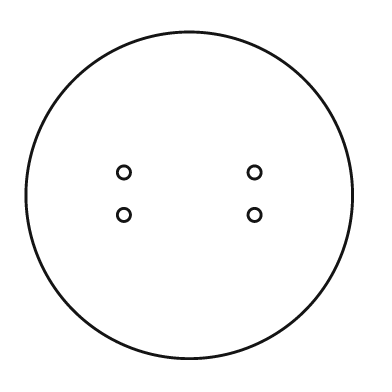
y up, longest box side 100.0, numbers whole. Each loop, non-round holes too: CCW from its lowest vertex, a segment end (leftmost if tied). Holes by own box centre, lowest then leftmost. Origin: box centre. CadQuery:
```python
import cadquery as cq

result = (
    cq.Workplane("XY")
    .moveTo(0.0, 0.0)
    .circle(50.0)
    .moveTo(-20.0, -6.0)
    .circle(2.0)
    .moveTo(20.0, -6.0)
    .circle(2.0)
    .moveTo(-20.0, 7.0)
    .circle(2.0)
    .moveTo(20.0, 7.0)
    .circle(2.0)
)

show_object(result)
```